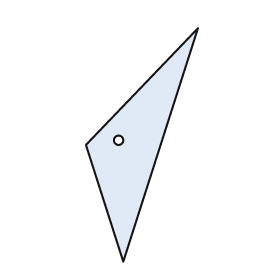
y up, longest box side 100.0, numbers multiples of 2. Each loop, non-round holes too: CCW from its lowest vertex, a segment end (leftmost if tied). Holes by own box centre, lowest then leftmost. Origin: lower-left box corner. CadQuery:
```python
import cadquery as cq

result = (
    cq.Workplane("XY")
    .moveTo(16.0, 0.0)
    .lineTo(48.0, 100.0)
    .lineTo(0.0, 50.0)
    .close()
    .moveTo(14.0, 52.0)
    .circle(2.0)
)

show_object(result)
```